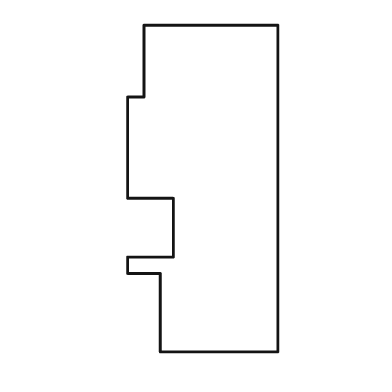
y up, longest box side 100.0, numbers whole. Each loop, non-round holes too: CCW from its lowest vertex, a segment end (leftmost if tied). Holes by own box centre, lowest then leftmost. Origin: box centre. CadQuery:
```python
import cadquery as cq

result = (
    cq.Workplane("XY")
    .moveTo(-13.0, -50.0)
    .lineTo(23.0, -50.0)
    .lineTo(23.0, 50.0)
    .lineTo(-18.0, 50.0)
    .lineTo(-18.0, 28.0)
    .lineTo(-23.0, 28.0)
    .lineTo(-23.0, -3.0)
    .lineTo(-9.0, -3.0)
    .lineTo(-9.0, -21.0)
    .lineTo(-23.0, -21.0)
    .lineTo(-23.0, -26.0)
    .lineTo(-13.0, -26.0)
    .close()
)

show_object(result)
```